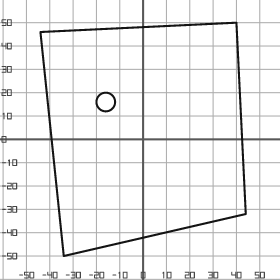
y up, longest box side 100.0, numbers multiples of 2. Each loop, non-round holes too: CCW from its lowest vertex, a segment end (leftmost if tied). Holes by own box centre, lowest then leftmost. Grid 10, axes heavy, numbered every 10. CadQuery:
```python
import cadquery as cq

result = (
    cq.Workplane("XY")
    .moveTo(-34.0, -50.0)
    .lineTo(44.0, -32.0)
    .lineTo(40.0, 50.0)
    .lineTo(-44.0, 46.0)
    .close()
    .moveTo(-16.0, 16.0)
    .circle(4.0)
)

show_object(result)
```